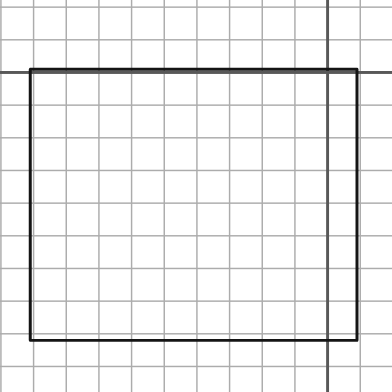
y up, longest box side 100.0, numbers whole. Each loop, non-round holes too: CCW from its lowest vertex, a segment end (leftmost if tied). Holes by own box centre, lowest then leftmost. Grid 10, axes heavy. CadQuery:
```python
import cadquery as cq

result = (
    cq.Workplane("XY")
    .moveTo(-91.0, -82.0)
    .lineTo(9.0, -82.0)
    .lineTo(9.0, 1.0)
    .lineTo(-91.0, 1.0)
    .close()
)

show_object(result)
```